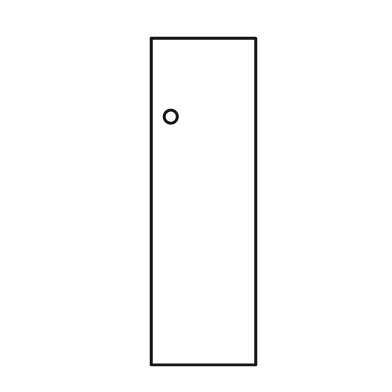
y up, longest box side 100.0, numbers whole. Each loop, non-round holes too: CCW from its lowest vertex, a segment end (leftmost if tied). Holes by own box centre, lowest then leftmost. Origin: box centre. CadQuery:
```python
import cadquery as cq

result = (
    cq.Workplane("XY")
    .moveTo(-16.0, -50.0)
    .lineTo(16.0, -50.0)
    .lineTo(16.0, 50.0)
    .lineTo(-16.0, 50.0)
    .close()
    .moveTo(-10.0, 26.0)
    .circle(2.0)
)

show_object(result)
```